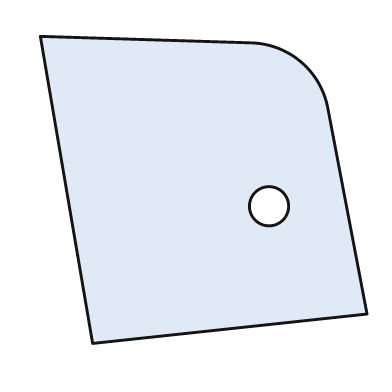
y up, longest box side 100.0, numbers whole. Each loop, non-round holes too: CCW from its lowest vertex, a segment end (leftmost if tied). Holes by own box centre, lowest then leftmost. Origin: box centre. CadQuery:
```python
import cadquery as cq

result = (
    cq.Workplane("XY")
    .moveTo(-34.0, -47.0)
    .lineTo(50.0, -38.0)
    .lineTo(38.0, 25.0)
    .threePointArc((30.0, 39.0), (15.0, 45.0))
    .lineTo(-50.0, 47.0)
    .close()
    .moveTo(20.0, -5.0)
    .circle(6.0)
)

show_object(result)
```